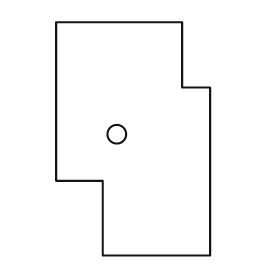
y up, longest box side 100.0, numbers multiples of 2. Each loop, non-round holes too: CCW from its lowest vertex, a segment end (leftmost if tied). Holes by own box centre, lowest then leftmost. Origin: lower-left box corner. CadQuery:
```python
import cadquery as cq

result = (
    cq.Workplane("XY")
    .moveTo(20.0, 0.0)
    .lineTo(66.0, 0.0)
    .lineTo(66.0, 72.0)
    .lineTo(54.0, 72.0)
    .lineTo(54.0, 100.0)
    .lineTo(0.0, 100.0)
    .lineTo(0.0, 32.0)
    .lineTo(20.0, 32.0)
    .close()
    .moveTo(26.0, 52.0)
    .circle(4.0)
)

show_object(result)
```